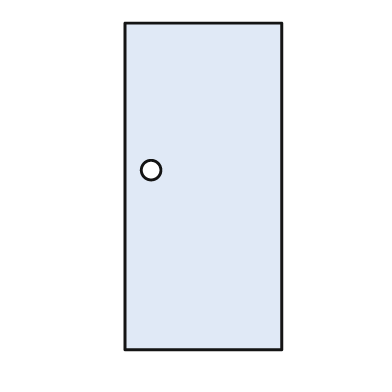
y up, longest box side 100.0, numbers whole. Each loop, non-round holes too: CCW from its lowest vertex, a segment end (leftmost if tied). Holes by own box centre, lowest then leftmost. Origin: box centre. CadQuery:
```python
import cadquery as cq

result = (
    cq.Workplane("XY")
    .moveTo(-24.0, -50.0)
    .lineTo(24.0, -50.0)
    .lineTo(24.0, 50.0)
    .lineTo(-24.0, 50.0)
    .close()
    .moveTo(-16.0, 5.0)
    .circle(3.0)
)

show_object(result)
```